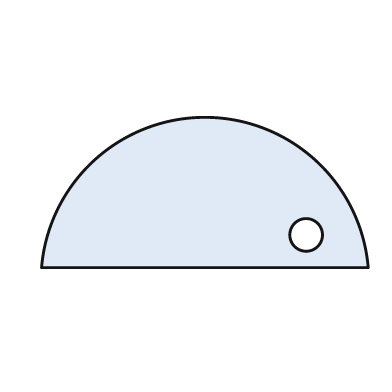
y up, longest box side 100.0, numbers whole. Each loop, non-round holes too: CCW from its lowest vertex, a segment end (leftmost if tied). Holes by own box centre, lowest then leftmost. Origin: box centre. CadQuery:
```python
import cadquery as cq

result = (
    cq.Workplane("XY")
    .moveTo(-50.0, -23.0)
    .lineTo(50.0, -23.0)
    .threePointArc((0.0, 23.0), (-50.0, -23.0))
    .close()
    .moveTo(31.0, -13.0)
    .circle(5.0)
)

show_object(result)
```